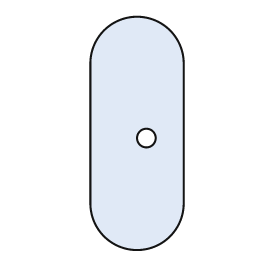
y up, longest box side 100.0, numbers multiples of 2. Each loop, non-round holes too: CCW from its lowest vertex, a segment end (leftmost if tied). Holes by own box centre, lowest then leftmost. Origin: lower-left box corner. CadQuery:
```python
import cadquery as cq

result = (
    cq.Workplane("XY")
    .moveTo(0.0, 20.0)
    .threePointArc((20.0, 0.0), (40.0, 20.0))
    .lineTo(40.0, 80.0)
    .threePointArc((20.0, 100.0), (0.0, 80.0))
    .close()
    .moveTo(24.0, 48.0)
    .circle(4.0)
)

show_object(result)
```